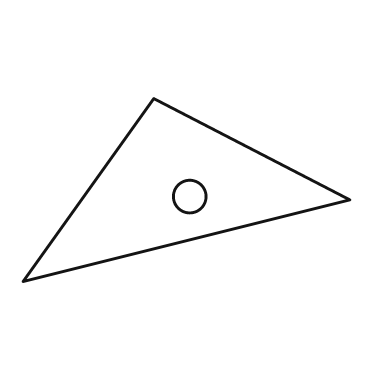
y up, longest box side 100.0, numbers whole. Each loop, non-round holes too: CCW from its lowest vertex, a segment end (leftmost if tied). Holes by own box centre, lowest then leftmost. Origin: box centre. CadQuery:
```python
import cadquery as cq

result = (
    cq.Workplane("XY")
    .moveTo(-50.0, -28.0)
    .lineTo(50.0, -3.0)
    .lineTo(-10.0, 28.0)
    .close()
    .moveTo(1.0, -2.0)
    .circle(5.0)
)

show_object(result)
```